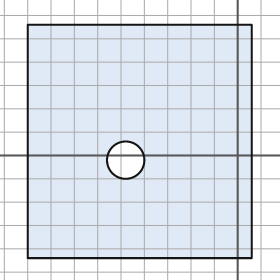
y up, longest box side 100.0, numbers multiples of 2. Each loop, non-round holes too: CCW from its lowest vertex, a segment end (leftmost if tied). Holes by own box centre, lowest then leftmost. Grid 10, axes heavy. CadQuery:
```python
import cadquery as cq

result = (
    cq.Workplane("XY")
    .moveTo(-90.0, -44.0)
    .lineTo(6.0, -44.0)
    .lineTo(6.0, 56.0)
    .lineTo(-90.0, 56.0)
    .close()
    .moveTo(-48.0, -2.0)
    .circle(8.0)
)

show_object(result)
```